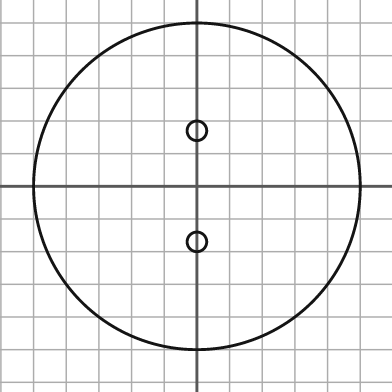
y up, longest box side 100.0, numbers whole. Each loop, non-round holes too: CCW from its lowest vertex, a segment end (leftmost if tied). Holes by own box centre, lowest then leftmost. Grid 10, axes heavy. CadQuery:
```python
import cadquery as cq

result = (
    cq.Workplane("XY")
    .moveTo(0.0, 0.0)
    .circle(50.0)
    .moveTo(0.0, -17.0)
    .circle(3.0)
    .moveTo(0.0, 17.0)
    .circle(3.0)
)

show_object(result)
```